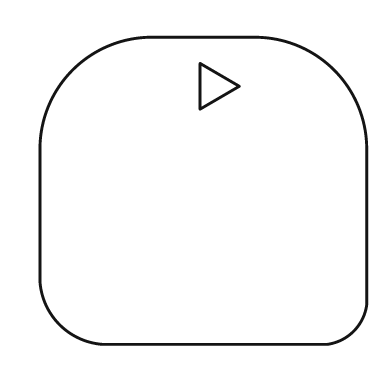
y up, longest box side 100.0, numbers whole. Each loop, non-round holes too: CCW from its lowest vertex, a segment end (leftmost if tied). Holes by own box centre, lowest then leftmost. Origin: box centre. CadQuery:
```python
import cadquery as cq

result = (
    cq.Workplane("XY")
    .moveTo(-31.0, -47.0)
    .lineTo(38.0, -47.0)
    .threePointArc((46.0, -43.0), (50.0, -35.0))
    .lineTo(50.0, 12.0)
    .threePointArc((40.0, 37.0), (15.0, 47.0))
    .lineTo(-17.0, 47.0)
    .threePointArc((-40.0, 37.0), (-50.0, 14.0))
    .lineTo(-50.0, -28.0)
    .threePointArc((-44.0, -41.0), (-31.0, -47.0))
    .close()
    .moveTo(-1.0, 25.0)
    .lineTo(11.0, 32.0)
    .lineTo(-1.0, 39.0)
    .close()
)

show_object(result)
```